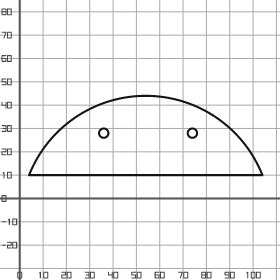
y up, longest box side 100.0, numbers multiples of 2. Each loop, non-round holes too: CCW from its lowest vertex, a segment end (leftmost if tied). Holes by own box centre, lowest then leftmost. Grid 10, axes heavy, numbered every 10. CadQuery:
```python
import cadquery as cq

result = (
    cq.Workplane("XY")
    .moveTo(4.0, 10.0)
    .lineTo(104.0, 10.0)
    .threePointArc((54.0, 44.0), (4.0, 10.0))
    .close()
    .moveTo(36.0, 28.0)
    .circle(2.0)
    .moveTo(74.0, 28.0)
    .circle(2.0)
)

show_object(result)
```